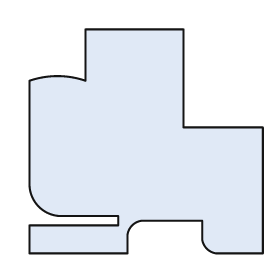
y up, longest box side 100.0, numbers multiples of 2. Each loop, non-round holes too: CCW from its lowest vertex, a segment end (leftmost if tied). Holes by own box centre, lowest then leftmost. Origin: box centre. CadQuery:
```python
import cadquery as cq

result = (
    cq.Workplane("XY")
    .moveTo(-50.0, -48.0)
    .lineTo(-8.0, -48.0)
    .lineTo(-8.0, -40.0)
    .threePointArc((-6.0, -36.0), (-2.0, -34.0))
    .lineTo(24.0, -34.0)
    .lineTo(24.0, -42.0)
    .threePointArc((26.0, -46.0), (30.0, -48.0))
    .lineTo(50.0, -48.0)
    .lineTo(50.0, 6.0)
    .lineTo(16.0, 6.0)
    .lineTo(16.0, 48.0)
    .lineTo(-26.0, 48.0)
    .lineTo(-26.0, 26.0)
    .threePointArc((-38.0, 28.0), (-50.0, 26.0))
    .lineTo(-50.0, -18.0)
    .threePointArc((-46.0, -28.0), (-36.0, -32.0))
    .lineTo(-12.0, -32.0)
    .lineTo(-12.0, -36.0)
    .lineTo(-50.0, -36.0)
    .close()
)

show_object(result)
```